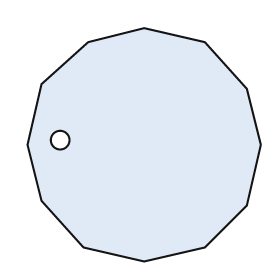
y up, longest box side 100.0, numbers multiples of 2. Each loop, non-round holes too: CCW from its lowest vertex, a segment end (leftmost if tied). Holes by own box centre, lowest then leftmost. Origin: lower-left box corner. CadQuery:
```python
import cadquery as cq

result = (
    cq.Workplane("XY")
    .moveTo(50.0, 0.0)
    .lineTo(76.0, 6.0)
    .lineTo(94.0, 24.0)
    .lineTo(100.0, 50.0)
    .lineTo(94.0, 74.0)
    .lineTo(76.0, 94.0)
    .lineTo(50.0, 100.0)
    .lineTo(26.0, 94.0)
    .lineTo(6.0, 76.0)
    .lineTo(0.0, 50.0)
    .lineTo(6.0, 26.0)
    .lineTo(24.0, 6.0)
    .close()
    .moveTo(14.0, 52.0)
    .circle(4.0)
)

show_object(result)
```